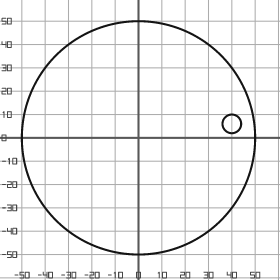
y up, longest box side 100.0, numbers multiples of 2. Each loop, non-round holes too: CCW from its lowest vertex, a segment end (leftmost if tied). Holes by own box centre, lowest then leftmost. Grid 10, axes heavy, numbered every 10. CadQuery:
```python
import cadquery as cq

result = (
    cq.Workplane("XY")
    .moveTo(0.0, 0.0)
    .circle(50.0)
    .moveTo(40.0, 6.0)
    .circle(4.0)
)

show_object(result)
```